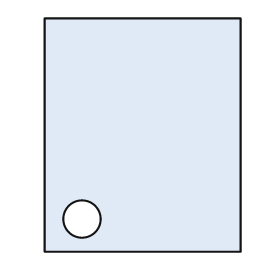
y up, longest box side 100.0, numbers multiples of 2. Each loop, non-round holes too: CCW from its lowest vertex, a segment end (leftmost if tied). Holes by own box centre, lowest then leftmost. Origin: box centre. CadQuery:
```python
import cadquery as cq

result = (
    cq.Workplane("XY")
    .moveTo(-42.0, -50.0)
    .lineTo(42.0, -50.0)
    .lineTo(42.0, 50.0)
    .lineTo(-42.0, 50.0)
    .close()
    .moveTo(-26.0, -36.0)
    .circle(8.0)
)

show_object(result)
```